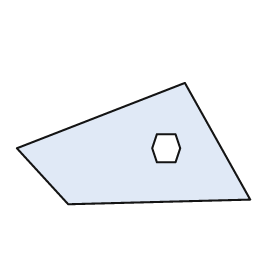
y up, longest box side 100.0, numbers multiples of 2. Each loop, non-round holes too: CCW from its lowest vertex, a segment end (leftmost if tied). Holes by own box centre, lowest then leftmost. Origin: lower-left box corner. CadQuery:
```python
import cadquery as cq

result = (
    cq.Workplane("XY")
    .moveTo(22.0, 0.0)
    .lineTo(100.0, 2.0)
    .lineTo(72.0, 52.0)
    .lineTo(0.0, 24.0)
    .close()
    .moveTo(60.0, 18.0)
    .lineTo(68.0, 18.0)
    .lineTo(70.0, 24.0)
    .lineTo(68.0, 30.0)
    .lineTo(60.0, 30.0)
    .lineTo(58.0, 24.0)
    .close()
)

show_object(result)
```